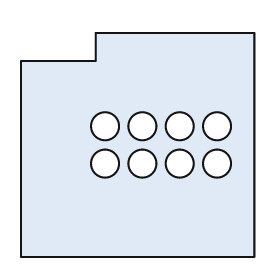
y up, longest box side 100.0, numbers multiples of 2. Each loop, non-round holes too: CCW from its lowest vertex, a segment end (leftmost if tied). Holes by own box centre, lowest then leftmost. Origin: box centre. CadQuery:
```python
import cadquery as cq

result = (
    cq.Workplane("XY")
    .moveTo(-50.0, -48.0)
    .lineTo(50.0, -48.0)
    .lineTo(50.0, 48.0)
    .lineTo(-18.0, 48.0)
    .lineTo(-18.0, 36.0)
    .lineTo(-50.0, 36.0)
    .close()
    .moveTo(-14.0, -8.0)
    .circle(6.0)
    .moveTo(2.0, -8.0)
    .circle(6.0)
    .moveTo(18.0, -8.0)
    .circle(6.0)
    .moveTo(34.0, -8.0)
    .circle(6.0)
    .moveTo(-14.0, 8.0)
    .circle(6.0)
    .moveTo(2.0, 8.0)
    .circle(6.0)
    .moveTo(18.0, 8.0)
    .circle(6.0)
    .moveTo(34.0, 8.0)
    .circle(6.0)
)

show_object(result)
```